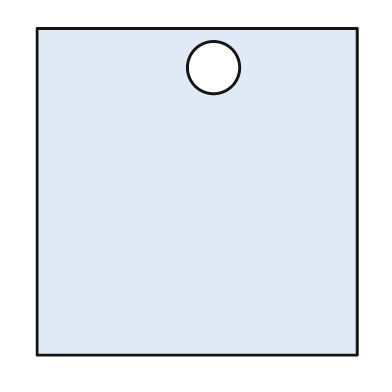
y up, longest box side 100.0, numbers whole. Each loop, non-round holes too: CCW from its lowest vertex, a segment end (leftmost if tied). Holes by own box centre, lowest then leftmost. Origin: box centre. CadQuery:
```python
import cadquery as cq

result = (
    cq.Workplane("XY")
    .moveTo(-49.0, -50.0)
    .lineTo(49.0, -50.0)
    .lineTo(49.0, 50.0)
    .lineTo(-49.0, 50.0)
    .close()
    .moveTo(5.0, 38.0)
    .circle(8.0)
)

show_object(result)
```